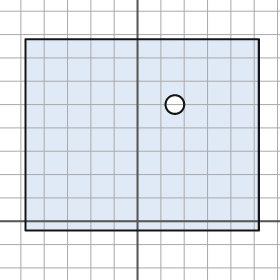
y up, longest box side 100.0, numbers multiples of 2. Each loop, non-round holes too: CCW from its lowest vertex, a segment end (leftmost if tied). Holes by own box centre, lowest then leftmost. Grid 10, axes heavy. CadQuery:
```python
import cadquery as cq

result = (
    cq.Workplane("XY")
    .moveTo(-48.0, -4.0)
    .lineTo(52.0, -4.0)
    .lineTo(52.0, 78.0)
    .lineTo(-48.0, 78.0)
    .close()
    .moveTo(16.0, 50.0)
    .circle(4.0)
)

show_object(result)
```